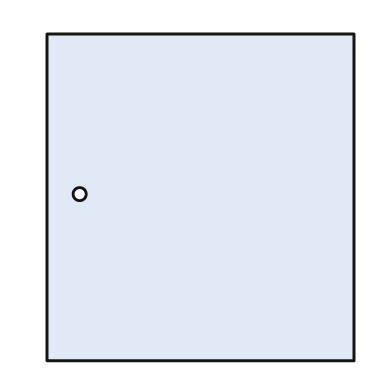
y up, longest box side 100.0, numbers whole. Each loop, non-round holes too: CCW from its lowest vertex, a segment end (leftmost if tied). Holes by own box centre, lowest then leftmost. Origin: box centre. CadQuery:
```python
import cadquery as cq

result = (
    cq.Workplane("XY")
    .moveTo(-47.0, -50.0)
    .lineTo(47.0, -50.0)
    .lineTo(47.0, 50.0)
    .lineTo(-47.0, 50.0)
    .close()
    .moveTo(-37.0, 1.0)
    .circle(2.0)
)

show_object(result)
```